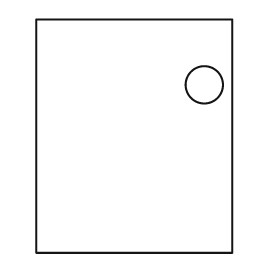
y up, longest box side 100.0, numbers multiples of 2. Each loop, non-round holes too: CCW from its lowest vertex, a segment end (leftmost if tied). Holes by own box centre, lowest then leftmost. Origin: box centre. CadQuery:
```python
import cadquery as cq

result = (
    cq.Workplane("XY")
    .moveTo(-42.0, -50.0)
    .lineTo(42.0, -50.0)
    .lineTo(42.0, 50.0)
    .lineTo(-42.0, 50.0)
    .close()
    .moveTo(30.0, 22.0)
    .circle(8.0)
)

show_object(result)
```